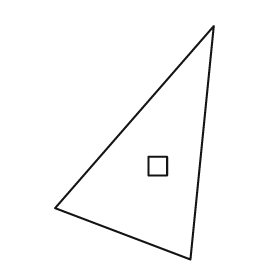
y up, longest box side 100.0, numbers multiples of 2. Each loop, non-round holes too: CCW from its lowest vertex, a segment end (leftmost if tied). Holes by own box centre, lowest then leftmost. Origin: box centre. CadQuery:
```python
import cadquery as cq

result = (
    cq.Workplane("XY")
    .moveTo(24.0, -50.0)
    .lineTo(34.0, 50.0)
    .lineTo(-34.0, -28.0)
    .close()
    .moveTo(6.0, -14.0)
    .lineTo(14.0, -14.0)
    .lineTo(14.0, -6.0)
    .lineTo(6.0, -6.0)
    .close()
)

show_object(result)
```